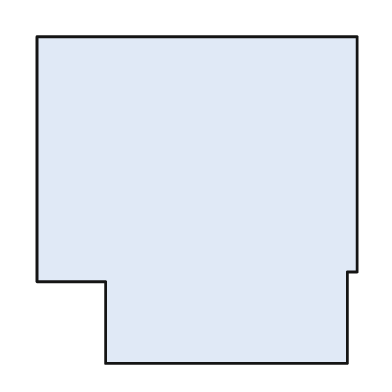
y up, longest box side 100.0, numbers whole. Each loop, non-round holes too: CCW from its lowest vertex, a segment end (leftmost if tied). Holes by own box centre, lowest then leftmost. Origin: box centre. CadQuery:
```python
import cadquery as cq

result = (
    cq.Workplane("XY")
    .moveTo(-28.0, -50.0)
    .lineTo(46.0, -50.0)
    .lineTo(46.0, -22.0)
    .lineTo(49.0, -22.0)
    .lineTo(49.0, 50.0)
    .lineTo(-49.0, 50.0)
    .lineTo(-49.0, -25.0)
    .lineTo(-28.0, -25.0)
    .close()
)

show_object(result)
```